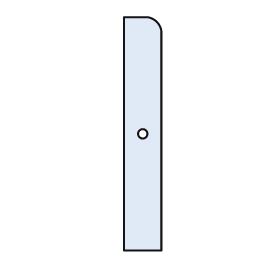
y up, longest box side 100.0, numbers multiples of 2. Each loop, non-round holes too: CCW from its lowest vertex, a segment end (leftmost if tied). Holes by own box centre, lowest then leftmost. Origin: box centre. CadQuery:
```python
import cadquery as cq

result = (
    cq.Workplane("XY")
    .moveTo(-8.0, -50.0)
    .lineTo(8.0, -50.0)
    .lineTo(8.0, 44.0)
    .threePointArc((6.0, 48.0), (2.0, 50.0))
    .lineTo(-8.0, 50.0)
    .close()
    .moveTo(0.0, 0.0)
    .circle(2.0)
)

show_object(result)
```